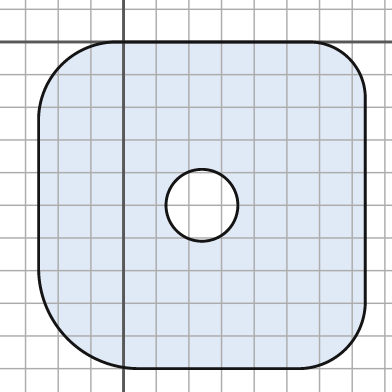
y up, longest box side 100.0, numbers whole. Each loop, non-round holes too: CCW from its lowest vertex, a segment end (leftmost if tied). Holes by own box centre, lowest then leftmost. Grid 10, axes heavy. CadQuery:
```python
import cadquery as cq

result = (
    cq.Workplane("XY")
    .moveTo(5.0, -100.0)
    .lineTo(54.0, -100.0)
    .threePointArc((68.0, -94.0), (74.0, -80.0))
    .lineTo(74.0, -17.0)
    .threePointArc((69.0, -5.0), (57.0, 0.0))
    .lineTo(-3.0, 0.0)
    .threePointArc((-19.0, -7.0), (-26.0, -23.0))
    .lineTo(-26.0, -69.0)
    .threePointArc((-17.0, -91.0), (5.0, -100.0))
    .close()
    .moveTo(24.0, -50.0)
    .circle(11.0)
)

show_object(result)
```